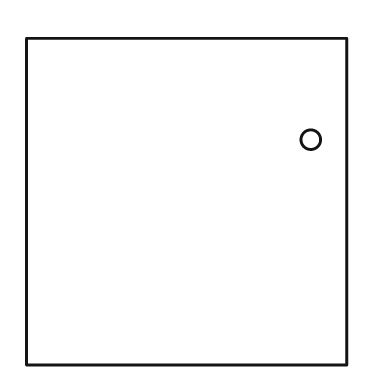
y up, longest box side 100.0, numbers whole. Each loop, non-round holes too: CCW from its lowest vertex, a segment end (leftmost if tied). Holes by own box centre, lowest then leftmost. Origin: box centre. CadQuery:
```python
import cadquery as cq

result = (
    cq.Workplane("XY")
    .moveTo(-49.0, -50.0)
    .lineTo(49.0, -50.0)
    .lineTo(49.0, 50.0)
    .lineTo(-49.0, 50.0)
    .close()
    .moveTo(38.0, 19.0)
    .circle(3.0)
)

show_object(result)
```